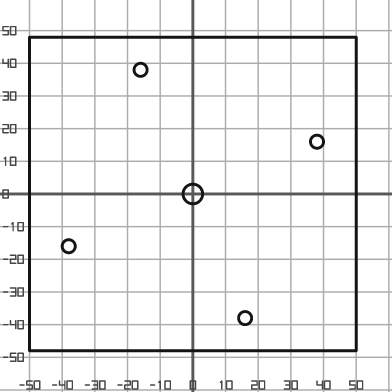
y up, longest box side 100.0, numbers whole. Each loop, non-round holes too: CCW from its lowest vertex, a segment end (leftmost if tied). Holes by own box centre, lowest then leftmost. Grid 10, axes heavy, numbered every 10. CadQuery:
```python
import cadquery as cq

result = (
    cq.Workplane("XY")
    .moveTo(-50.0, -48.0)
    .lineTo(50.0, -48.0)
    .lineTo(50.0, 48.0)
    .lineTo(-50.0, 48.0)
    .close()
    .moveTo(16.0, -38.0)
    .circle(2.0)
    .moveTo(-38.0, -16.0)
    .circle(2.0)
    .moveTo(0.0, 0.0)
    .circle(3.0)
    .moveTo(38.0, 16.0)
    .circle(2.0)
    .moveTo(-16.0, 38.0)
    .circle(2.0)
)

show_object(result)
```